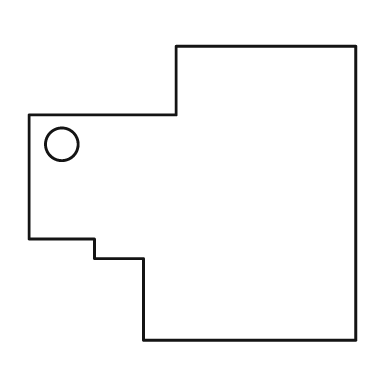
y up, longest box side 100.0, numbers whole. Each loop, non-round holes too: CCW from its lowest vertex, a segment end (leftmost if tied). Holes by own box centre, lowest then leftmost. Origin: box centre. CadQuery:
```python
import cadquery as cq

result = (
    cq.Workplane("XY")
    .moveTo(-15.0, -45.0)
    .lineTo(50.0, -45.0)
    .lineTo(50.0, 45.0)
    .lineTo(-5.0, 45.0)
    .lineTo(-5.0, 24.0)
    .lineTo(-50.0, 24.0)
    .lineTo(-50.0, -14.0)
    .lineTo(-30.0, -14.0)
    .lineTo(-30.0, -20.0)
    .lineTo(-15.0, -20.0)
    .close()
    .moveTo(-40.0, 15.0)
    .circle(5.0)
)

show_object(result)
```